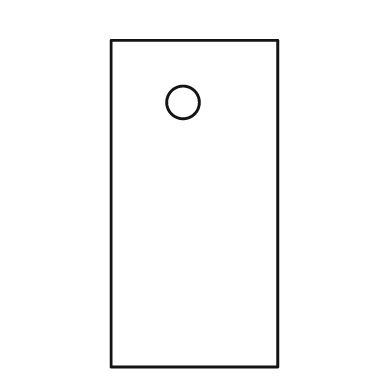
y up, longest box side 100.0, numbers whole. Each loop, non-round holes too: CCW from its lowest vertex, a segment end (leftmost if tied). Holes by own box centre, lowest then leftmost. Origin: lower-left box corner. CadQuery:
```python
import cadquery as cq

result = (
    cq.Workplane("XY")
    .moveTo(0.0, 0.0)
    .lineTo(51.0, 0.0)
    .lineTo(51.0, 100.0)
    .lineTo(0.0, 100.0)
    .close()
    .moveTo(22.0, 81.0)
    .circle(5.0)
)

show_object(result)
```